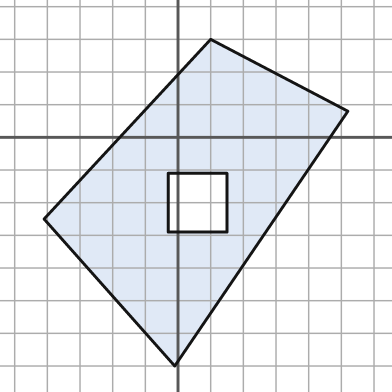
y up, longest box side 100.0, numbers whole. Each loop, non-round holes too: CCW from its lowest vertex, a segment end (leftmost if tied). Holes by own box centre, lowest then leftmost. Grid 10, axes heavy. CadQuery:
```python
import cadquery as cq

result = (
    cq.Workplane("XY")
    .moveTo(-1.0, -70.0)
    .lineTo(52.0, 8.0)
    .lineTo(10.0, 30.0)
    .lineTo(-41.0, -25.0)
    .close()
    .moveTo(-3.0, -29.0)
    .lineTo(15.0, -29.0)
    .lineTo(15.0, -11.0)
    .lineTo(-3.0, -11.0)
    .close()
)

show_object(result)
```